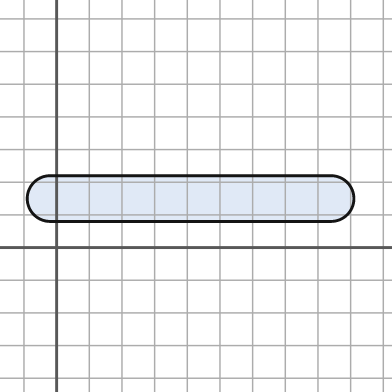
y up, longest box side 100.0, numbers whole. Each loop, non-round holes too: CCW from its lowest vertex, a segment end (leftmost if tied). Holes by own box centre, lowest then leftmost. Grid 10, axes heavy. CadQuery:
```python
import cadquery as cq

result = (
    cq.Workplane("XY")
    .moveTo(-2.0, 8.0)
    .lineTo(84.0, 8.0)
    .threePointArc((91.0, 15.0), (84.0, 22.0))
    .lineTo(-2.0, 22.0)
    .threePointArc((-9.0, 15.0), (-2.0, 8.0))
    .close()
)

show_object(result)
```